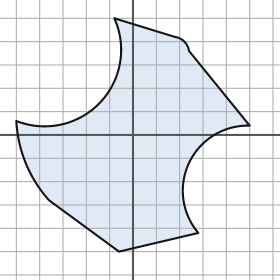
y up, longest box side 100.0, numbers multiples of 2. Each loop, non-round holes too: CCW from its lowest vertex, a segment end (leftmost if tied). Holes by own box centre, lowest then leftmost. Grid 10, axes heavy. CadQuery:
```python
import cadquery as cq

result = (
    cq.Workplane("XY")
    .moveTo(-6.0, -50.0)
    .lineTo(28.0, -42.0)
    .threePointArc((24.0, -12.0), (50.0, 4.0))
    .lineTo(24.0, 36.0)
    .threePointArc((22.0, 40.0), (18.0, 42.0))
    .lineTo(-8.0, 50.0)
    .threePointArc((-14.0, 14.0), (-50.0, 6.0))
    .threePointArc((-46.0, -12.0), (-36.0, -28.0))
    .close()
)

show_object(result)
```